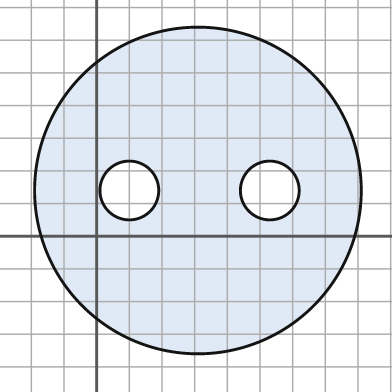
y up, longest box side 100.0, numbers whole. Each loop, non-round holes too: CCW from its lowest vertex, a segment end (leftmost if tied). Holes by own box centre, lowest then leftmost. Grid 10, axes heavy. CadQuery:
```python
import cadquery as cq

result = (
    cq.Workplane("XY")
    .moveTo(31.0, 14.0)
    .circle(50.0)
    .moveTo(10.0, 14.0)
    .circle(9.0)
    .moveTo(53.0, 14.0)
    .circle(9.0)
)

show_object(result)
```